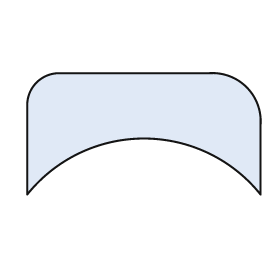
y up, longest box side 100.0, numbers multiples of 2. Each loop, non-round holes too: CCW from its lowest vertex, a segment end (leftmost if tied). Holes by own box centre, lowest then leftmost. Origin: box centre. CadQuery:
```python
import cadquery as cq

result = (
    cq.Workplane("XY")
    .moveTo(-50.0, -26.0)
    .threePointArc((0.0, -2.0), (50.0, -26.0))
    .lineTo(50.0, 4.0)
    .threePointArc((44.0, 20.0), (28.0, 26.0))
    .lineTo(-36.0, 26.0)
    .threePointArc((-46.0, 22.0), (-50.0, 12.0))
    .close()
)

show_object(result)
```